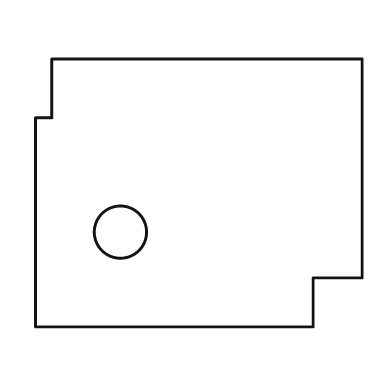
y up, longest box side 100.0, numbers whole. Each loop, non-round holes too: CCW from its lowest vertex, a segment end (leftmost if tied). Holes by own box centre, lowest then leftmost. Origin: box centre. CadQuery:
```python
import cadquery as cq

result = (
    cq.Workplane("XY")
    .moveTo(-50.0, -41.0)
    .lineTo(35.0, -41.0)
    .lineTo(35.0, -26.0)
    .lineTo(50.0, -26.0)
    .lineTo(50.0, 41.0)
    .lineTo(-45.0, 41.0)
    .lineTo(-45.0, 23.0)
    .lineTo(-50.0, 23.0)
    .close()
    .moveTo(-24.0, -12.0)
    .circle(8.0)
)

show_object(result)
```